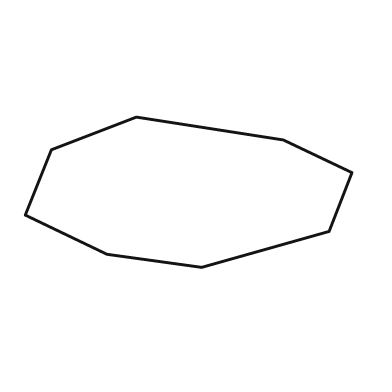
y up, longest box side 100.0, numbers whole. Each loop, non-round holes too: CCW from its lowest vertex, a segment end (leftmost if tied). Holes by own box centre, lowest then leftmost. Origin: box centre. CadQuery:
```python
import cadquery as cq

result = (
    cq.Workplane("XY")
    .moveTo(4.0, -23.0)
    .lineTo(43.0, -12.0)
    .lineTo(50.0, 6.0)
    .lineTo(29.0, 16.0)
    .lineTo(-16.0, 23.0)
    .lineTo(-42.0, 13.0)
    .lineTo(-50.0, -7.0)
    .lineTo(-25.0, -19.0)
    .close()
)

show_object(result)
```